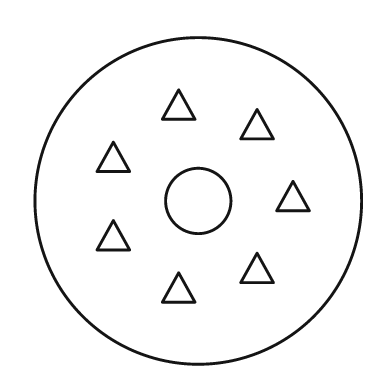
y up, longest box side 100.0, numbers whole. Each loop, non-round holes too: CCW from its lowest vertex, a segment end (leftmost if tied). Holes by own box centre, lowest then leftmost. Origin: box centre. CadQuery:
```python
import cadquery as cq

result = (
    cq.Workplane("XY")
    .moveTo(0.0, 0.0)
    .circle(50.0)
    .moveTo(-11.0, -31.0)
    .lineTo(-1.0, -31.0)
    .lineTo(-6.0, -22.0)
    .close()
    .moveTo(13.0, -25.0)
    .lineTo(23.0, -25.0)
    .lineTo(18.0, -16.0)
    .close()
    .moveTo(-31.0, -15.0)
    .lineTo(-21.0, -15.0)
    .lineTo(-26.0, -6.0)
    .close()
    .moveTo(0.0, 0.0)
    .circle(10.0)
    .moveTo(24.0, -3.0)
    .lineTo(34.0, -3.0)
    .lineTo(29.0, 6.0)
    .close()
    .moveTo(-31.0, 9.0)
    .lineTo(-21.0, 9.0)
    .lineTo(-26.0, 18.0)
    .close()
    .moveTo(13.0, 19.0)
    .lineTo(23.0, 19.0)
    .lineTo(18.0, 28.0)
    .close()
    .moveTo(-11.0, 25.0)
    .lineTo(-1.0, 25.0)
    .lineTo(-6.0, 34.0)
    .close()
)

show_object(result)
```